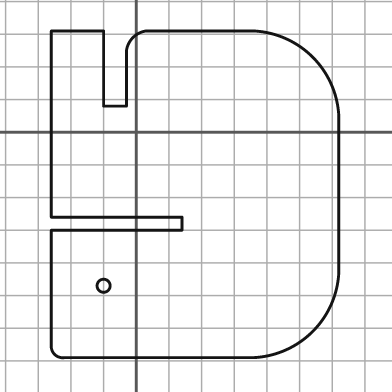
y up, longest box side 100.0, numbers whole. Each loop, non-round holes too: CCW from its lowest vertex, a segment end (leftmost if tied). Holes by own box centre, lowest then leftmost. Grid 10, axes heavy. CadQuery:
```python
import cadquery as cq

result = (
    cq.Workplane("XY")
    .moveTo(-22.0, -69.0)
    .lineTo(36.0, -69.0)
    .threePointArc((54.0, -61.0), (62.0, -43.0))
    .lineTo(62.0, 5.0)
    .threePointArc((54.0, 23.0), (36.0, 31.0))
    .lineTo(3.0, 31.0)
    .threePointArc((-1.0, 29.0), (-3.0, 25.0))
    .lineTo(-3.0, 8.0)
    .lineTo(-10.0, 8.0)
    .lineTo(-10.0, 31.0)
    .lineTo(-26.0, 31.0)
    .lineTo(-26.0, -26.0)
    .lineTo(14.0, -26.0)
    .lineTo(14.0, -30.0)
    .lineTo(-26.0, -30.0)
    .lineTo(-26.0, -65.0)
    .threePointArc((-25.0, -68.0), (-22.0, -69.0))
    .close()
    .moveTo(-10.0, -47.0)
    .circle(2.0)
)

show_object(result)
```